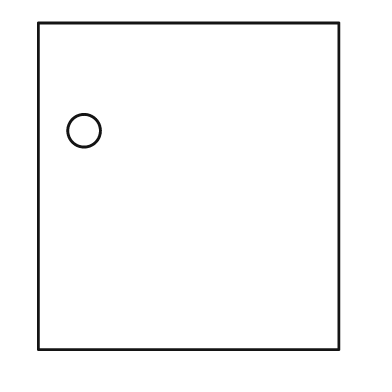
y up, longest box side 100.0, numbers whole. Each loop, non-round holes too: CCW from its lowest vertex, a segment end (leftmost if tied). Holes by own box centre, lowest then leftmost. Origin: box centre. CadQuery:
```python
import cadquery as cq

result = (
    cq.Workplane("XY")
    .moveTo(-46.0, -50.0)
    .lineTo(46.0, -50.0)
    .lineTo(46.0, 50.0)
    .lineTo(-46.0, 50.0)
    .close()
    .moveTo(-32.0, 17.0)
    .circle(5.0)
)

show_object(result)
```